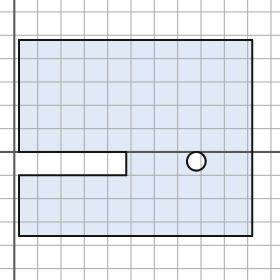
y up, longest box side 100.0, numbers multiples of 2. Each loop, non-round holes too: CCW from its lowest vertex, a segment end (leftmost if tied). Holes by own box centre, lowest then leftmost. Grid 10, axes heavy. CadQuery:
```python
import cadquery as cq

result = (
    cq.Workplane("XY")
    .moveTo(2.0, -36.0)
    .lineTo(102.0, -36.0)
    .lineTo(102.0, 48.0)
    .lineTo(2.0, 48.0)
    .lineTo(2.0, 0.0)
    .lineTo(48.0, 0.0)
    .lineTo(48.0, -10.0)
    .lineTo(2.0, -10.0)
    .close()
    .moveTo(78.0, -4.0)
    .circle(4.0)
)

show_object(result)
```